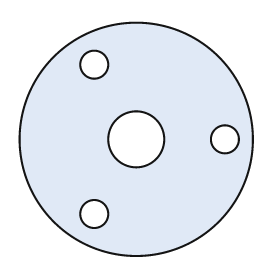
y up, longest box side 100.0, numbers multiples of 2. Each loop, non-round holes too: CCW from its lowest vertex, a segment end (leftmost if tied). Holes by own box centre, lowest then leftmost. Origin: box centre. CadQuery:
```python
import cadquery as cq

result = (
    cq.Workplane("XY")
    .moveTo(0.0, 0.0)
    .circle(50.0)
    .moveTo(-18.0, -32.0)
    .circle(6.0)
    .moveTo(0.0, 0.0)
    .circle(12.0)
    .moveTo(38.0, 0.0)
    .circle(6.0)
    .moveTo(-18.0, 32.0)
    .circle(6.0)
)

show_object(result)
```